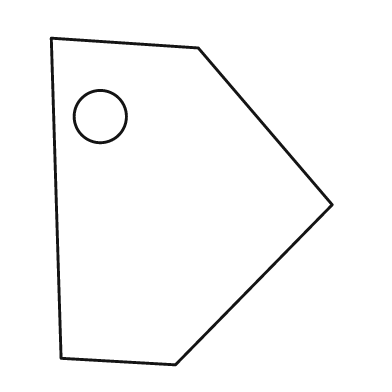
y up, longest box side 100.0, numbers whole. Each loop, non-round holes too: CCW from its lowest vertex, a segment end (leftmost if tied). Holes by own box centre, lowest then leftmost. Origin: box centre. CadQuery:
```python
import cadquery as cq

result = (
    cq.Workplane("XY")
    .moveTo(-5.0, -50.0)
    .lineTo(43.0, -1.0)
    .lineTo(2.0, 47.0)
    .lineTo(-43.0, 50.0)
    .lineTo(-40.0, -48.0)
    .close()
    .moveTo(-28.0, 26.0)
    .circle(8.0)
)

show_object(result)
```